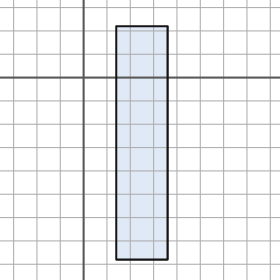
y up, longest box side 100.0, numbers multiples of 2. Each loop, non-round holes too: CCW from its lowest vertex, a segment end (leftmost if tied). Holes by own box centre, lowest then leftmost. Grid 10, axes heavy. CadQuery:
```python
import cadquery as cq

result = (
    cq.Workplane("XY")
    .moveTo(14.0, -78.0)
    .lineTo(36.0, -78.0)
    .lineTo(36.0, 22.0)
    .lineTo(14.0, 22.0)
    .close()
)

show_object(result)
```